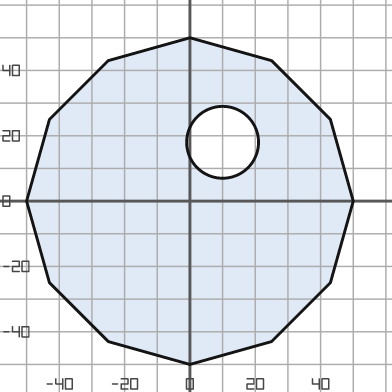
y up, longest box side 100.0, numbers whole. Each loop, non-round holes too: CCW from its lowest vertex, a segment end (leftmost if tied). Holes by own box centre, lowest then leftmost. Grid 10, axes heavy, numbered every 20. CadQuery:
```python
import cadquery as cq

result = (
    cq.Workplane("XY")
    .moveTo(0.0, -50.0)
    .lineTo(25.0, -43.0)
    .lineTo(43.0, -25.0)
    .lineTo(50.0, 0.0)
    .lineTo(43.0, 25.0)
    .lineTo(25.0, 43.0)
    .lineTo(0.0, 50.0)
    .lineTo(-25.0, 43.0)
    .lineTo(-43.0, 25.0)
    .lineTo(-50.0, 0.0)
    .lineTo(-43.0, -25.0)
    .lineTo(-25.0, -43.0)
    .close()
    .moveTo(10.0, 18.0)
    .circle(11.0)
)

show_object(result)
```